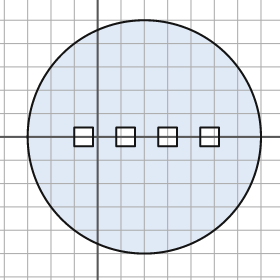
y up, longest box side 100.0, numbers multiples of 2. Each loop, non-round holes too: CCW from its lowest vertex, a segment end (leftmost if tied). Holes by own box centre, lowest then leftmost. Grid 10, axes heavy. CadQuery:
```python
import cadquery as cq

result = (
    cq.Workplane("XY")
    .moveTo(20.0, 0.0)
    .circle(50.0)
    .moveTo(-10.0, -4.0)
    .lineTo(-2.0, -4.0)
    .lineTo(-2.0, 4.0)
    .lineTo(-10.0, 4.0)
    .close()
    .moveTo(8.0, -4.0)
    .lineTo(16.0, -4.0)
    .lineTo(16.0, 4.0)
    .lineTo(8.0, 4.0)
    .close()
    .moveTo(26.0, -4.0)
    .lineTo(34.0, -4.0)
    .lineTo(34.0, 4.0)
    .lineTo(26.0, 4.0)
    .close()
    .moveTo(44.0, -4.0)
    .lineTo(52.0, -4.0)
    .lineTo(52.0, 4.0)
    .lineTo(44.0, 4.0)
    .close()
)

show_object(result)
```